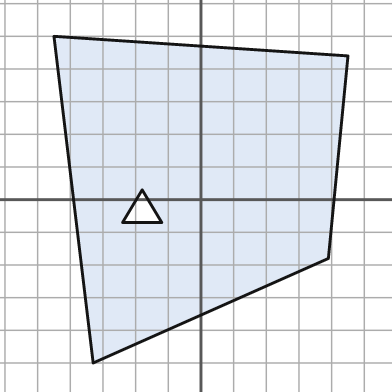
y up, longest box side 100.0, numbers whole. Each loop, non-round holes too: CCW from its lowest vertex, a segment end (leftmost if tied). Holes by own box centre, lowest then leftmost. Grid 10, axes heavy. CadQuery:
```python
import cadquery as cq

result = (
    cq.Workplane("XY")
    .moveTo(-33.0, -50.0)
    .lineTo(39.0, -18.0)
    .lineTo(45.0, 44.0)
    .lineTo(-45.0, 50.0)
    .close()
    .moveTo(-24.0, -7.0)
    .lineTo(-12.0, -7.0)
    .lineTo(-18.0, 3.0)
    .close()
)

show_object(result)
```